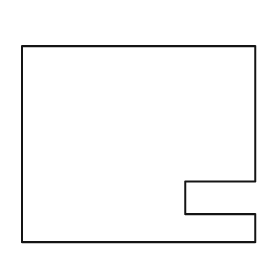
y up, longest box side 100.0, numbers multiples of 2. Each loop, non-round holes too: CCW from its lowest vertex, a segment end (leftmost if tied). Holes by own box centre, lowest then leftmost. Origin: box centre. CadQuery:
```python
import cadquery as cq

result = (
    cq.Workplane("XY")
    .moveTo(-50.0, -42.0)
    .lineTo(50.0, -42.0)
    .lineTo(50.0, -30.0)
    .lineTo(20.0, -30.0)
    .lineTo(20.0, -16.0)
    .lineTo(50.0, -16.0)
    .lineTo(50.0, 42.0)
    .lineTo(-50.0, 42.0)
    .close()
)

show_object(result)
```